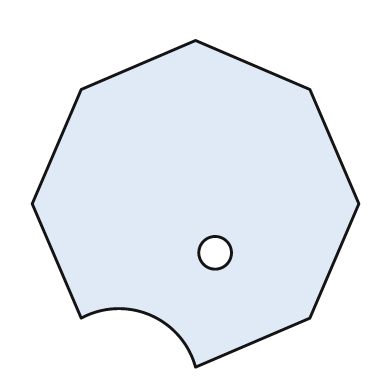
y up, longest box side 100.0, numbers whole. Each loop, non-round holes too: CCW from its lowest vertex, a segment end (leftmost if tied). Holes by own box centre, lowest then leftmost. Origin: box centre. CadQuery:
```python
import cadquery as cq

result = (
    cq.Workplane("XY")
    .moveTo(0.0, -50.0)
    .lineTo(35.0, -35.0)
    .lineTo(50.0, 0.0)
    .lineTo(35.0, 35.0)
    .lineTo(0.0, 50.0)
    .lineTo(-35.0, 35.0)
    .lineTo(-50.0, 0.0)
    .lineTo(-35.0, -35.0)
    .threePointArc((-14.0, -34.0), (0.0, -50.0))
    .close()
    .moveTo(6.0, -15.0)
    .circle(5.0)
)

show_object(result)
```